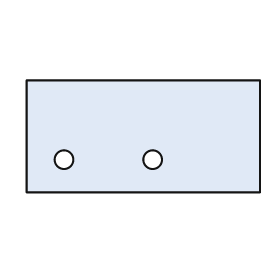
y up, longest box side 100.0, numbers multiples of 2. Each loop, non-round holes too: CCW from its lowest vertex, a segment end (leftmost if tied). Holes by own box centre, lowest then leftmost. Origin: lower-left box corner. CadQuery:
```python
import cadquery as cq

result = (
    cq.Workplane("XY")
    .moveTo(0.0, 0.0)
    .lineTo(100.0, 0.0)
    .lineTo(100.0, 48.0)
    .lineTo(0.0, 48.0)
    .close()
    .moveTo(16.0, 14.0)
    .circle(4.0)
    .moveTo(54.0, 14.0)
    .circle(4.0)
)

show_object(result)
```